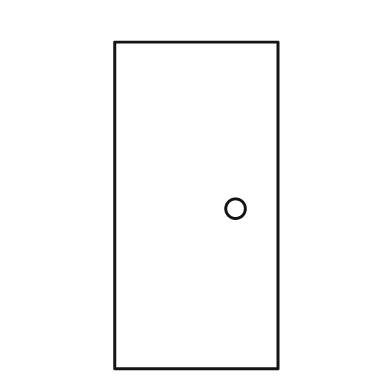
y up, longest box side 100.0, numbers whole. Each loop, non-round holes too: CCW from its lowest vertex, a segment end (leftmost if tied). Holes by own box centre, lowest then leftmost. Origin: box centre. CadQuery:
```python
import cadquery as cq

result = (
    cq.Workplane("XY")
    .moveTo(-25.0, -50.0)
    .lineTo(25.0, -50.0)
    .lineTo(25.0, 50.0)
    .lineTo(-25.0, 50.0)
    .close()
    .moveTo(12.0, -1.0)
    .circle(3.0)
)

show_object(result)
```